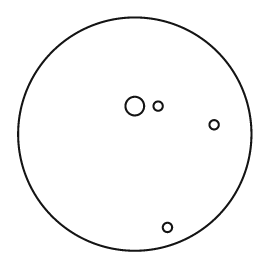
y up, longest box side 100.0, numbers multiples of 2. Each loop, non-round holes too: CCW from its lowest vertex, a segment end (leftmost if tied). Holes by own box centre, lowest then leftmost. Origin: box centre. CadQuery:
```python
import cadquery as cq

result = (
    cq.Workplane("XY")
    .moveTo(0.0, 0.0)
    .circle(50.0)
    .moveTo(14.0, -40.0)
    .circle(2.0)
    .moveTo(34.0, 4.0)
    .circle(2.0)
    .moveTo(0.0, 12.0)
    .circle(4.0)
    .moveTo(10.0, 12.0)
    .circle(2.0)
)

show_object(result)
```